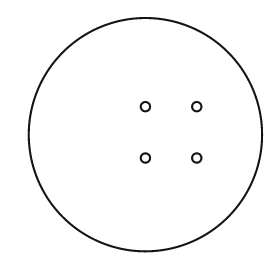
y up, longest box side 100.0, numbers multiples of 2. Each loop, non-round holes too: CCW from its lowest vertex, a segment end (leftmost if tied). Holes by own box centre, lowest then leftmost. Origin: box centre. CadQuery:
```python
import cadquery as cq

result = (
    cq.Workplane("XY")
    .moveTo(0.0, 0.0)
    .circle(50.0)
    .moveTo(0.0, -10.0)
    .circle(2.0)
    .moveTo(22.0, -10.0)
    .circle(2.0)
    .moveTo(0.0, 12.0)
    .circle(2.0)
    .moveTo(22.0, 12.0)
    .circle(2.0)
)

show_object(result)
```